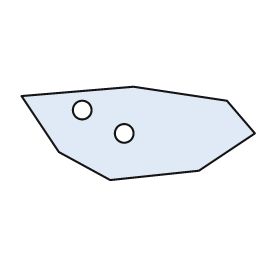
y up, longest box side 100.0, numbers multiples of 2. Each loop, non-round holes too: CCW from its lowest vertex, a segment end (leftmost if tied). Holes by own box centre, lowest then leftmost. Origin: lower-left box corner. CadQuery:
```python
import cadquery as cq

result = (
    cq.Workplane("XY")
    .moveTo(38.0, 0.0)
    .lineTo(76.0, 4.0)
    .lineTo(100.0, 20.0)
    .lineTo(88.0, 34.0)
    .lineTo(48.0, 40.0)
    .lineTo(0.0, 36.0)
    .lineTo(16.0, 12.0)
    .close()
    .moveTo(44.0, 20.0)
    .circle(4.0)
    .moveTo(26.0, 30.0)
    .circle(4.0)
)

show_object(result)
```